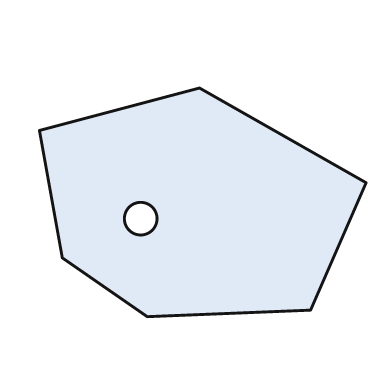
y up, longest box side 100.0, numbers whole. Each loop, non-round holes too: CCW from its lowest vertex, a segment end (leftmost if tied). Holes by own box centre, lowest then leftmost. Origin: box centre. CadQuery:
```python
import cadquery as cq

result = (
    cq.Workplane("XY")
    .moveTo(-17.0, -35.0)
    .lineTo(33.0, -33.0)
    .lineTo(50.0, 6.0)
    .lineTo(-1.0, 35.0)
    .lineTo(-50.0, 22.0)
    .lineTo(-43.0, -17.0)
    .close()
    .moveTo(-19.0, -5.0)
    .circle(5.0)
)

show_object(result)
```